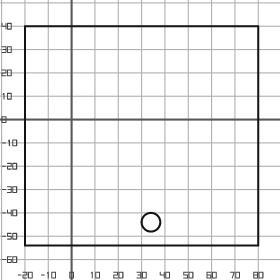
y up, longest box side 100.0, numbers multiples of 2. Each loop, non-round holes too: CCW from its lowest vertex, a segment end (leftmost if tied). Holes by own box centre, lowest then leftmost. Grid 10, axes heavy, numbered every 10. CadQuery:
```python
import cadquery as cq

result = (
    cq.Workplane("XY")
    .moveTo(-20.0, -54.0)
    .lineTo(80.0, -54.0)
    .lineTo(80.0, 40.0)
    .lineTo(-20.0, 40.0)
    .close()
    .moveTo(34.0, -44.0)
    .circle(4.0)
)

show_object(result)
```